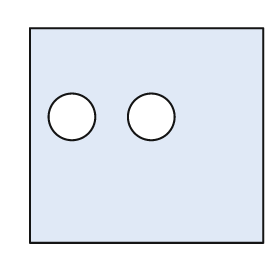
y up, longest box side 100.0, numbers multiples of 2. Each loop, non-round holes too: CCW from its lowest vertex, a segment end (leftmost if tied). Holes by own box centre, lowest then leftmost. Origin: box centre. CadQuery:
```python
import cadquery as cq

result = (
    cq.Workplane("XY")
    .moveTo(-50.0, -46.0)
    .lineTo(50.0, -46.0)
    .lineTo(50.0, 46.0)
    .lineTo(-50.0, 46.0)
    .close()
    .moveTo(-32.0, 8.0)
    .circle(10.0)
    .moveTo(2.0, 8.0)
    .circle(10.0)
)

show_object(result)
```